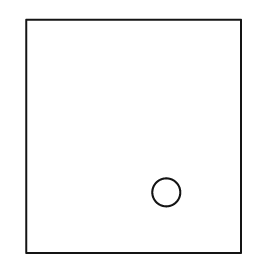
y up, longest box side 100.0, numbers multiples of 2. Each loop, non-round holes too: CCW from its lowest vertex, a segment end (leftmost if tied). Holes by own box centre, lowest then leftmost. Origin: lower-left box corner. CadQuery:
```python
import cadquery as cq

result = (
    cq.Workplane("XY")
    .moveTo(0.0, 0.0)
    .lineTo(92.0, 0.0)
    .lineTo(92.0, 100.0)
    .lineTo(0.0, 100.0)
    .close()
    .moveTo(60.0, 26.0)
    .circle(6.0)
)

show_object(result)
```